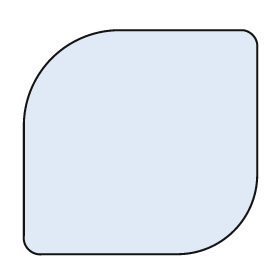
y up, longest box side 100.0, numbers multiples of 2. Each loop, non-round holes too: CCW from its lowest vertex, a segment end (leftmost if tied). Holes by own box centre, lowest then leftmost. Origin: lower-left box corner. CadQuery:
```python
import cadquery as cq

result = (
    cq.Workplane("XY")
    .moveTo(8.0, 0.0)
    .lineTo(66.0, 0.0)
    .threePointArc((90.0, 10.0), (100.0, 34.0))
    .lineTo(100.0, 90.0)
    .threePointArc((98.0, 94.0), (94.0, 96.0))
    .lineTo(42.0, 96.0)
    .threePointArc((12.0, 84.0), (0.0, 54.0))
    .lineTo(0.0, 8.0)
    .threePointArc((2.0, 2.0), (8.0, 0.0))
    .close()
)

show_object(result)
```